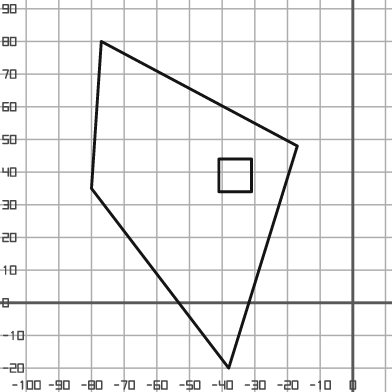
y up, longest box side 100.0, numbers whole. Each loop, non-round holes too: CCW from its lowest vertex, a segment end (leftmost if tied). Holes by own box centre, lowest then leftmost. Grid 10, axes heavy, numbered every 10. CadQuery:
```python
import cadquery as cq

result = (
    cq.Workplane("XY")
    .moveTo(-38.0, -20.0)
    .lineTo(-17.0, 48.0)
    .lineTo(-77.0, 80.0)
    .lineTo(-80.0, 35.0)
    .close()
    .moveTo(-41.0, 34.0)
    .lineTo(-31.0, 34.0)
    .lineTo(-31.0, 44.0)
    .lineTo(-41.0, 44.0)
    .close()
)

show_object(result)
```